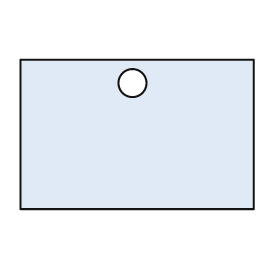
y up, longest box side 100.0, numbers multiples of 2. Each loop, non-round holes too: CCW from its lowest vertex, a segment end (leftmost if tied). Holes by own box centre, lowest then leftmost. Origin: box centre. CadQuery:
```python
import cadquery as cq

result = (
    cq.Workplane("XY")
    .moveTo(-50.0, -32.0)
    .lineTo(50.0, -32.0)
    .lineTo(50.0, 32.0)
    .lineTo(-50.0, 32.0)
    .close()
    .moveTo(-2.0, 22.0)
    .circle(6.0)
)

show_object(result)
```